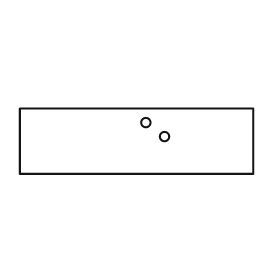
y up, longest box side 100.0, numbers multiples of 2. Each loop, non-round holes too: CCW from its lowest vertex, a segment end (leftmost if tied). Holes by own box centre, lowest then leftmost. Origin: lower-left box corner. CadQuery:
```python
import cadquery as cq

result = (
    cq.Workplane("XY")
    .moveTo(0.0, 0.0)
    .lineTo(100.0, 0.0)
    .lineTo(100.0, 28.0)
    .lineTo(0.0, 28.0)
    .close()
    .moveTo(62.0, 16.0)
    .circle(2.0)
    .moveTo(54.0, 22.0)
    .circle(2.0)
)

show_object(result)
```